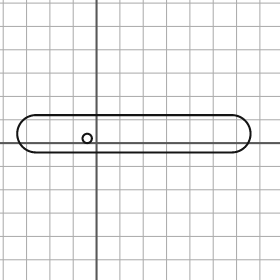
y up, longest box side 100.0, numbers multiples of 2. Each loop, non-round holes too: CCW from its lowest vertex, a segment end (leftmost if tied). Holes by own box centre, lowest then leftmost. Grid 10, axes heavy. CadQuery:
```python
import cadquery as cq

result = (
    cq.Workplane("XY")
    .moveTo(-26.0, -4.0)
    .lineTo(58.0, -4.0)
    .threePointArc((66.0, 4.0), (58.0, 12.0))
    .lineTo(-26.0, 12.0)
    .threePointArc((-34.0, 4.0), (-26.0, -4.0))
    .close()
    .moveTo(-4.0, 2.0)
    .circle(2.0)
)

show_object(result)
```